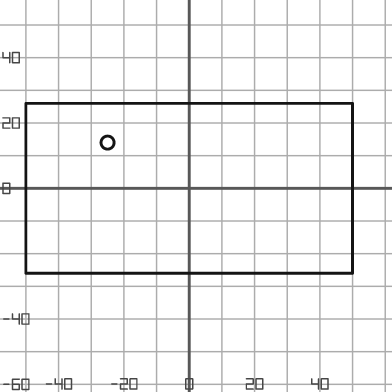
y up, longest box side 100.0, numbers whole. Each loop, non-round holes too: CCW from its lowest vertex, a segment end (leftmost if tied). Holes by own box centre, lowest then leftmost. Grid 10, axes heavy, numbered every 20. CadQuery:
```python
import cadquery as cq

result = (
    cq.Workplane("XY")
    .moveTo(-50.0, -26.0)
    .lineTo(50.0, -26.0)
    .lineTo(50.0, 26.0)
    .lineTo(-50.0, 26.0)
    .close()
    .moveTo(-25.0, 14.0)
    .circle(2.0)
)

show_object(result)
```